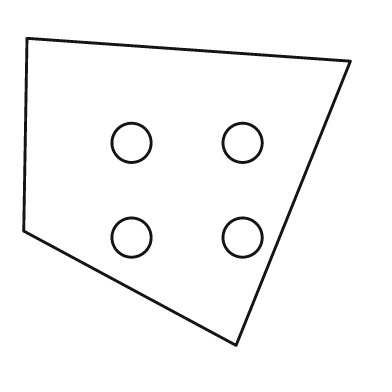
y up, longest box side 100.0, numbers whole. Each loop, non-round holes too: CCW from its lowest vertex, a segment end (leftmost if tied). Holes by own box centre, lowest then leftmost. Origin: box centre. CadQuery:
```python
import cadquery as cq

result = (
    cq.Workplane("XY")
    .moveTo(15.0, -47.0)
    .lineTo(50.0, 40.0)
    .lineTo(-49.0, 47.0)
    .lineTo(-50.0, -12.0)
    .close()
    .moveTo(-17.0, -14.0)
    .circle(6.0)
    .moveTo(17.0, -14.0)
    .circle(6.0)
    .moveTo(-17.0, 15.0)
    .circle(6.0)
    .moveTo(17.0, 15.0)
    .circle(6.0)
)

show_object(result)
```